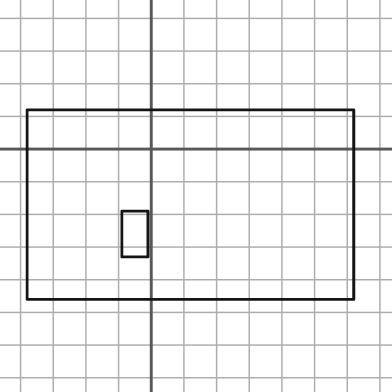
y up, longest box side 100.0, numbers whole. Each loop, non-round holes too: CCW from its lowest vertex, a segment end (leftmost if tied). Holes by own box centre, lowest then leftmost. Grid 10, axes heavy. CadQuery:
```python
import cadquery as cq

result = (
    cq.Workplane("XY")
    .moveTo(-38.0, -46.0)
    .lineTo(62.0, -46.0)
    .lineTo(62.0, 12.0)
    .lineTo(-38.0, 12.0)
    .close()
    .moveTo(-9.0, -33.0)
    .lineTo(-1.0, -33.0)
    .lineTo(-1.0, -19.0)
    .lineTo(-9.0, -19.0)
    .close()
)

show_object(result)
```